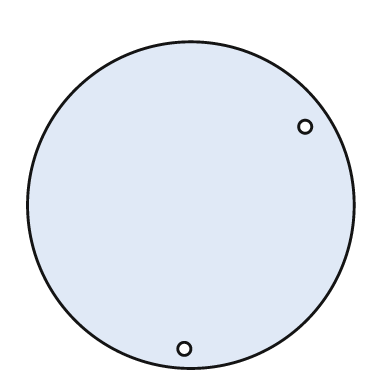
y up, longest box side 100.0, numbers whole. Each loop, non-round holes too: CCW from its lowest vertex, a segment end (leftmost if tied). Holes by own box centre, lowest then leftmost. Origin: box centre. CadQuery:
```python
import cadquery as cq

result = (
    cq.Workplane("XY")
    .moveTo(0.0, 0.0)
    .circle(50.0)
    .moveTo(-2.0, -44.0)
    .circle(2.0)
    .moveTo(35.0, 24.0)
    .circle(2.0)
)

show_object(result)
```